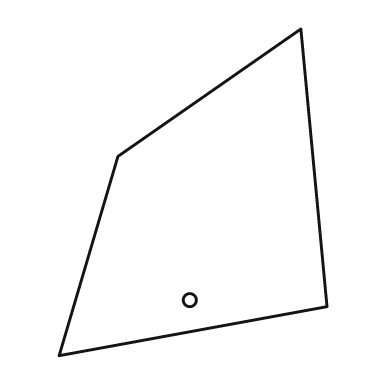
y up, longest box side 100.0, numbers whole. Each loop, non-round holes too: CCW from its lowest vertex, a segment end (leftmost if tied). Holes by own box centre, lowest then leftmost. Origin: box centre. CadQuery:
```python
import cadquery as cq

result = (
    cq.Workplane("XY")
    .moveTo(-41.0, -50.0)
    .lineTo(41.0, -35.0)
    .lineTo(33.0, 50.0)
    .lineTo(-23.0, 11.0)
    .close()
    .moveTo(-1.0, -33.0)
    .circle(2.0)
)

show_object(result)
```